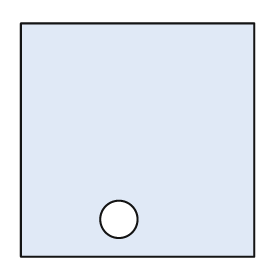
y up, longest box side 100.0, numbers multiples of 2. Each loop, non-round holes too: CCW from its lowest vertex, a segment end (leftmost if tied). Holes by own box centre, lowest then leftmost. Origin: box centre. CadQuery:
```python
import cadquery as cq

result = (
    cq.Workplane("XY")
    .moveTo(-50.0, -50.0)
    .lineTo(50.0, -50.0)
    .lineTo(50.0, 50.0)
    .lineTo(-50.0, 50.0)
    .close()
    .moveTo(-8.0, -34.0)
    .circle(8.0)
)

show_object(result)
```